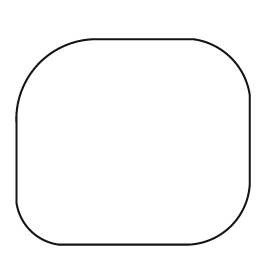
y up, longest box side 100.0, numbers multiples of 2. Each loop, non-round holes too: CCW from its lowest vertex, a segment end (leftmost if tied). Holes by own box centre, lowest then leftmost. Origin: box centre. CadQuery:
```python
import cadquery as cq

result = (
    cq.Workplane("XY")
    .moveTo(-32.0, -44.0)
    .lineTo(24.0, -44.0)
    .threePointArc((42.0, -36.0), (50.0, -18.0))
    .lineTo(50.0, 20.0)
    .threePointArc((42.0, 36.0), (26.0, 44.0))
    .lineTo(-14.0, 44.0)
    .threePointArc((-40.0, 34.0), (-50.0, 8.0))
    .lineTo(-50.0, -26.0)
    .threePointArc((-44.0, -38.0), (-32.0, -44.0))
    .close()
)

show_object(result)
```